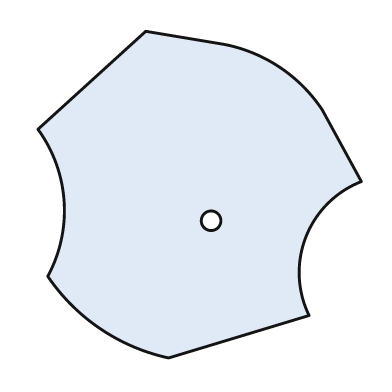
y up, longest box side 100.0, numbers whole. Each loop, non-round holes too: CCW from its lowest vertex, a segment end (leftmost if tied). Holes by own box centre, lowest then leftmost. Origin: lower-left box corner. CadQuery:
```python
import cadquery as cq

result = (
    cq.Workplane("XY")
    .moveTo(40.0, 0.0)
    .lineTo(83.0, 13.0)
    .threePointArc((82.0, 37.0), (99.0, 54.0))
    .lineTo(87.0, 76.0)
    .threePointArc((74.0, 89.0), (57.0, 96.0))
    .lineTo(33.0, 100.0)
    .lineTo(0.0, 70.0)
    .threePointArc((8.0, 48.0), (3.0, 25.0))
    .threePointArc((19.0, 9.0), (40.0, 0.0))
    .close()
    .moveTo(53.0, 42.0)
    .circle(3.0)
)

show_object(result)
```